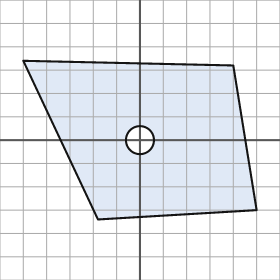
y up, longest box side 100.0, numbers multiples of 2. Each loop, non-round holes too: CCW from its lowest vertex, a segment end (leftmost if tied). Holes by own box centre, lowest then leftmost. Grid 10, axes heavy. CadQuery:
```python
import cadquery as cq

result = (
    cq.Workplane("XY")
    .moveTo(-18.0, -34.0)
    .lineTo(50.0, -30.0)
    .lineTo(40.0, 32.0)
    .lineTo(-50.0, 34.0)
    .close()
    .moveTo(0.0, 0.0)
    .circle(6.0)
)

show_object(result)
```